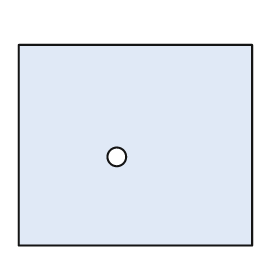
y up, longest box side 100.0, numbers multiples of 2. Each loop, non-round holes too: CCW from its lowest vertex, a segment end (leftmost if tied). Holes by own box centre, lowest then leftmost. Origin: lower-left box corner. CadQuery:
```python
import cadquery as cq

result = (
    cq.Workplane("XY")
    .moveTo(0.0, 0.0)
    .lineTo(100.0, 0.0)
    .lineTo(100.0, 86.0)
    .lineTo(0.0, 86.0)
    .close()
    .moveTo(42.0, 38.0)
    .circle(4.0)
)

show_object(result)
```